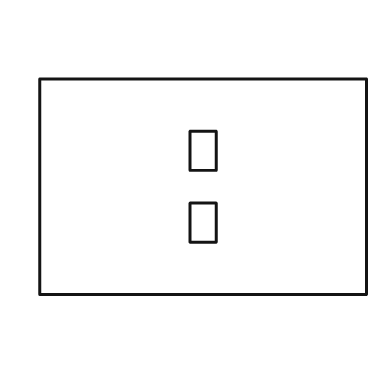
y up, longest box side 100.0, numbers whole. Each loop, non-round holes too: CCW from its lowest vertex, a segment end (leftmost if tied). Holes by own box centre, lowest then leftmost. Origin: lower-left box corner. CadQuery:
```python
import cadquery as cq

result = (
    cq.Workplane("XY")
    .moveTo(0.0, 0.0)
    .lineTo(100.0, 0.0)
    .lineTo(100.0, 66.0)
    .lineTo(0.0, 66.0)
    .close()
    .moveTo(46.0, 16.0)
    .lineTo(54.0, 16.0)
    .lineTo(54.0, 28.0)
    .lineTo(46.0, 28.0)
    .close()
    .moveTo(46.0, 38.0)
    .lineTo(54.0, 38.0)
    .lineTo(54.0, 50.0)
    .lineTo(46.0, 50.0)
    .close()
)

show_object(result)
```